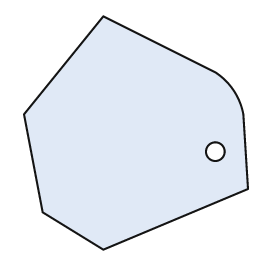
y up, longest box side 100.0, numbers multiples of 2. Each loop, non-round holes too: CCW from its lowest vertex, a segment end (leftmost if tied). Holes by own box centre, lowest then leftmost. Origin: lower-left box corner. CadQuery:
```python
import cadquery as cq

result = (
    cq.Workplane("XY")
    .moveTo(34.0, 0.0)
    .lineTo(96.0, 26.0)
    .lineTo(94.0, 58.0)
    .threePointArc((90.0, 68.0), (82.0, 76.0))
    .lineTo(34.0, 100.0)
    .lineTo(0.0, 58.0)
    .lineTo(8.0, 16.0)
    .close()
    .moveTo(82.0, 42.0)
    .circle(4.0)
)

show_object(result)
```